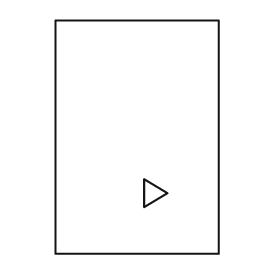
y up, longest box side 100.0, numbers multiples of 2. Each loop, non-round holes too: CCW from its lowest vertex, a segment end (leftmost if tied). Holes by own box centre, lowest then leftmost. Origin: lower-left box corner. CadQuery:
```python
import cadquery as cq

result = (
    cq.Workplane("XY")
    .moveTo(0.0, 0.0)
    .lineTo(70.0, 0.0)
    .lineTo(70.0, 100.0)
    .lineTo(0.0, 100.0)
    .close()
    .moveTo(38.0, 20.0)
    .lineTo(48.0, 26.0)
    .lineTo(38.0, 32.0)
    .close()
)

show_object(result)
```